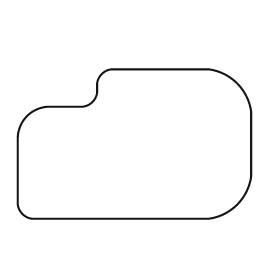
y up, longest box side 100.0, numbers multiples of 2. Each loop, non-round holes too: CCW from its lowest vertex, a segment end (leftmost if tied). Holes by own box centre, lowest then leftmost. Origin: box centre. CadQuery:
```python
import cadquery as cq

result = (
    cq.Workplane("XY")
    .moveTo(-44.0, -32.0)
    .lineTo(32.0, -32.0)
    .threePointArc((44.0, -26.0), (50.0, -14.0))
    .lineTo(50.0, 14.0)
    .threePointArc((44.0, 26.0), (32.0, 32.0))
    .lineTo(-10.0, 32.0)
    .threePointArc((-14.0, 30.0), (-16.0, 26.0))
    .lineTo(-16.0, 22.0)
    .threePointArc((-18.0, 18.0), (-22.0, 16.0))
    .lineTo(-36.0, 16.0)
    .threePointArc((-46.0, 12.0), (-50.0, 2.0))
    .lineTo(-50.0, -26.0)
    .threePointArc((-48.0, -30.0), (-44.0, -32.0))
    .close()
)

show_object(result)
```